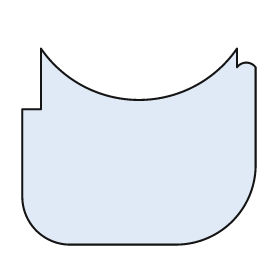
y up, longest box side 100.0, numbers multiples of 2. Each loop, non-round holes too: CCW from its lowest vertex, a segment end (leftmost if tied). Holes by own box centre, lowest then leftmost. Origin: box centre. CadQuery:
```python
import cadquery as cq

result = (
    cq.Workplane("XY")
    .moveTo(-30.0, -42.0)
    .lineTo(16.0, -42.0)
    .threePointArc((40.0, -32.0), (50.0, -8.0))
    .lineTo(50.0, 34.0)
    .threePointArc((46.0, 36.0), (42.0, 34.0))
    .lineTo(42.0, 42.0)
    .threePointArc((0.0, 20.0), (-42.0, 42.0))
    .lineTo(-42.0, 16.0)
    .lineTo(-50.0, 16.0)
    .lineTo(-50.0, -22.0)
    .threePointArc((-44.0, -36.0), (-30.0, -42.0))
    .close()
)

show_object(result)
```